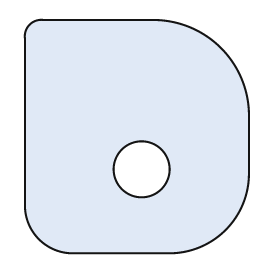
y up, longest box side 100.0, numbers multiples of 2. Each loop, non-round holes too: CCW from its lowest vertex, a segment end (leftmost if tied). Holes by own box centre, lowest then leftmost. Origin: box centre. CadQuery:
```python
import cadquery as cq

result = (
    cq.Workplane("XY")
    .moveTo(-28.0, -50.0)
    .lineTo(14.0, -50.0)
    .threePointArc((38.0, -40.0), (48.0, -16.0))
    .lineTo(48.0, 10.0)
    .threePointArc((36.0, 38.0), (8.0, 50.0))
    .lineTo(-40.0, 50.0)
    .threePointArc((-46.0, 48.0), (-48.0, 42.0))
    .lineTo(-48.0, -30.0)
    .threePointArc((-42.0, -44.0), (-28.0, -50.0))
    .close()
    .moveTo(2.0, -14.0)
    .circle(12.0)
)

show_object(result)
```